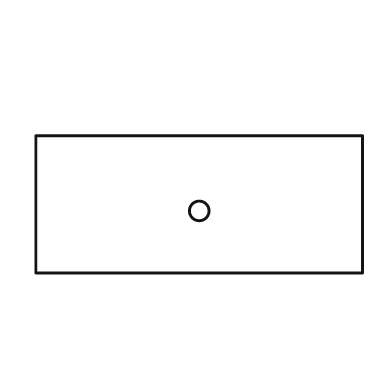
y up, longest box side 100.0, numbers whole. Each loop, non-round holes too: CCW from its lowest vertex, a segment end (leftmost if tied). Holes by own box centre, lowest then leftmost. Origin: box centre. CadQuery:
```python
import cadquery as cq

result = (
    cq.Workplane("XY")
    .moveTo(-50.0, -21.0)
    .lineTo(50.0, -21.0)
    .lineTo(50.0, 21.0)
    .lineTo(-50.0, 21.0)
    .close()
    .moveTo(0.0, -2.0)
    .circle(3.0)
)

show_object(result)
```